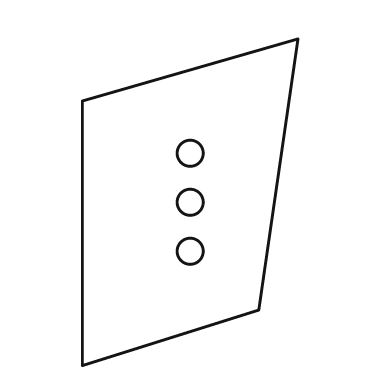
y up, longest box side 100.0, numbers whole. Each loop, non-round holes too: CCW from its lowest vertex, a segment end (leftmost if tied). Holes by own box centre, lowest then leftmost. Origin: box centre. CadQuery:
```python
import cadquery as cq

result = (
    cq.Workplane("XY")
    .moveTo(-33.0, -50.0)
    .lineTo(21.0, -33.0)
    .lineTo(33.0, 50.0)
    .lineTo(-33.0, 31.0)
    .close()
    .moveTo(0.0, -15.0)
    .circle(4.0)
    .moveTo(0.0, 0.0)
    .circle(4.0)
    .moveTo(0.0, 15.0)
    .circle(4.0)
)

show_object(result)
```